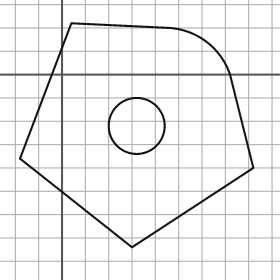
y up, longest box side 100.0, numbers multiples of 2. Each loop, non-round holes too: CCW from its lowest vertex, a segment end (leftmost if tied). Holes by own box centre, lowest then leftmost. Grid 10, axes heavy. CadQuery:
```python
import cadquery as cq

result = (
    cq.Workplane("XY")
    .moveTo(30.0, -74.0)
    .lineTo(82.0, -40.0)
    .lineTo(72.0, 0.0)
    .threePointArc((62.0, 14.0), (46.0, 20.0))
    .lineTo(4.0, 22.0)
    .lineTo(-18.0, -36.0)
    .close()
    .moveTo(32.0, -22.0)
    .circle(12.0)
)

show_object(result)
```